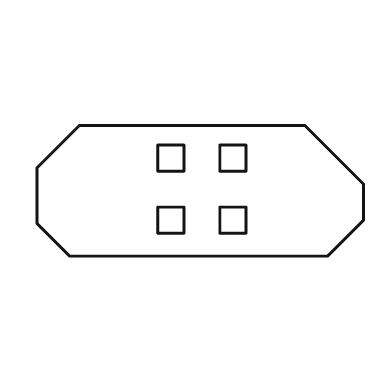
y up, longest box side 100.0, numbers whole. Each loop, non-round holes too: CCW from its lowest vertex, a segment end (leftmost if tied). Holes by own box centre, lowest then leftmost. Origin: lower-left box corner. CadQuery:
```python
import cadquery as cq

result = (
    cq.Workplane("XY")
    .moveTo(10.0, 0.0)
    .lineTo(89.0, 0.0)
    .lineTo(100.0, 11.0)
    .lineTo(100.0, 22.0)
    .lineTo(82.0, 40.0)
    .lineTo(13.0, 40.0)
    .lineTo(0.0, 27.0)
    .lineTo(0.0, 10.0)
    .close()
    .moveTo(37.0, 7.0)
    .lineTo(45.0, 7.0)
    .lineTo(45.0, 15.0)
    .lineTo(37.0, 15.0)
    .close()
    .moveTo(56.0, 7.0)
    .lineTo(64.0, 7.0)
    .lineTo(64.0, 15.0)
    .lineTo(56.0, 15.0)
    .close()
    .moveTo(37.0, 26.0)
    .lineTo(45.0, 26.0)
    .lineTo(45.0, 34.0)
    .lineTo(37.0, 34.0)
    .close()
    .moveTo(56.0, 26.0)
    .lineTo(64.0, 26.0)
    .lineTo(64.0, 34.0)
    .lineTo(56.0, 34.0)
    .close()
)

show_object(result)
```